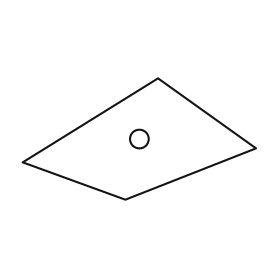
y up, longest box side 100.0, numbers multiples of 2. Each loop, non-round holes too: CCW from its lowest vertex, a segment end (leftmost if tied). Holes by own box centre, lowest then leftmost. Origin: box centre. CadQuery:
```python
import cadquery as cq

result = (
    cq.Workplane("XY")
    .moveTo(-6.0, -26.0)
    .lineTo(50.0, -4.0)
    .lineTo(8.0, 26.0)
    .lineTo(-50.0, -10.0)
    .close()
    .moveTo(0.0, 0.0)
    .circle(4.0)
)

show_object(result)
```